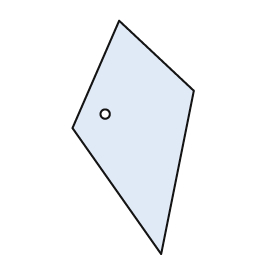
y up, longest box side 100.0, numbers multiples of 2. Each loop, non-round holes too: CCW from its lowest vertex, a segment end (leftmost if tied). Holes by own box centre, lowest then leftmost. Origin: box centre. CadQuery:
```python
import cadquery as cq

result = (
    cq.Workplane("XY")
    .moveTo(12.0, -50.0)
    .lineTo(26.0, 20.0)
    .lineTo(-6.0, 50.0)
    .lineTo(-26.0, 4.0)
    .close()
    .moveTo(-12.0, 10.0)
    .circle(2.0)
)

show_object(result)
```